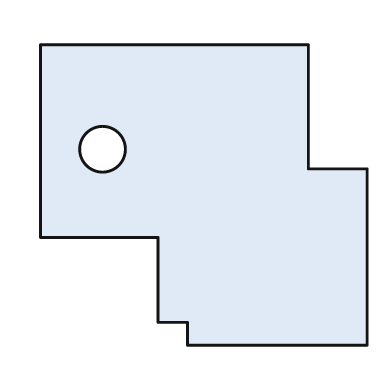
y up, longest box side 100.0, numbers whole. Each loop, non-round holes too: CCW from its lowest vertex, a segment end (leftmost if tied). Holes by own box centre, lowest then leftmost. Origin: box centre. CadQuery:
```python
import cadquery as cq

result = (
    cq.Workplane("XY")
    .moveTo(-5.0, -46.0)
    .lineTo(50.0, -46.0)
    .lineTo(50.0, 8.0)
    .lineTo(32.0, 8.0)
    .lineTo(32.0, 46.0)
    .lineTo(-50.0, 46.0)
    .lineTo(-50.0, -13.0)
    .lineTo(-14.0, -13.0)
    .lineTo(-14.0, -39.0)
    .lineTo(-5.0, -39.0)
    .close()
    .moveTo(-31.0, 14.0)
    .circle(7.0)
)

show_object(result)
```